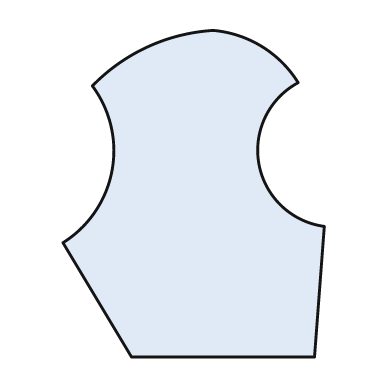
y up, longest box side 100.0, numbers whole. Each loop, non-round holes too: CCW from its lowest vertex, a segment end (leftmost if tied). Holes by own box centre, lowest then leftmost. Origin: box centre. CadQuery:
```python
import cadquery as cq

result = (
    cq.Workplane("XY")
    .moveTo(-19.0, -50.0)
    .lineTo(37.0, -50.0)
    .lineTo(40.0, -10.0)
    .threePointArc((20.0, 9.0), (32.0, 34.0))
    .threePointArc((21.0, 45.0), (6.0, 50.0))
    .threePointArc((-14.0, 45.0), (-31.0, 33.0))
    .threePointArc((-25.0, 7.0), (-40.0, -15.0))
    .close()
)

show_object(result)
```